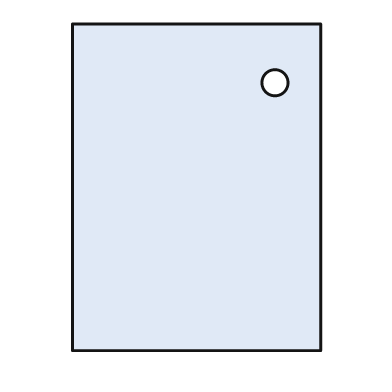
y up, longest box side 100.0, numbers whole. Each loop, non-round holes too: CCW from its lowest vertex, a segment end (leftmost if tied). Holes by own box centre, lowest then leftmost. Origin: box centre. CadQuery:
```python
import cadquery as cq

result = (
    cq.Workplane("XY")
    .moveTo(-38.0, -50.0)
    .lineTo(38.0, -50.0)
    .lineTo(38.0, 50.0)
    .lineTo(-38.0, 50.0)
    .close()
    .moveTo(24.0, 32.0)
    .circle(4.0)
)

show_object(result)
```